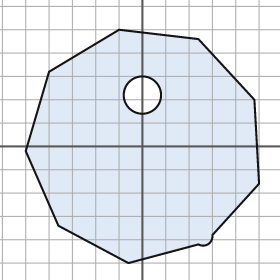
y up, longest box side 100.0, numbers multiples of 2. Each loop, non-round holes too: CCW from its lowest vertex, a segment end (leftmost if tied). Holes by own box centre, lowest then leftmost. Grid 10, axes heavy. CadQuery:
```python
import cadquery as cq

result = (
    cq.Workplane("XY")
    .moveTo(-6.0, -50.0)
    .lineTo(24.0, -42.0)
    .threePointArc((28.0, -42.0), (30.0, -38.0))
    .lineTo(50.0, -16.0)
    .lineTo(48.0, 20.0)
    .lineTo(24.0, 46.0)
    .lineTo(-10.0, 50.0)
    .lineTo(-40.0, 32.0)
    .lineTo(-50.0, -2.0)
    .lineTo(-36.0, -34.0)
    .close()
    .moveTo(0.0, 22.0)
    .circle(8.0)
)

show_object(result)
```